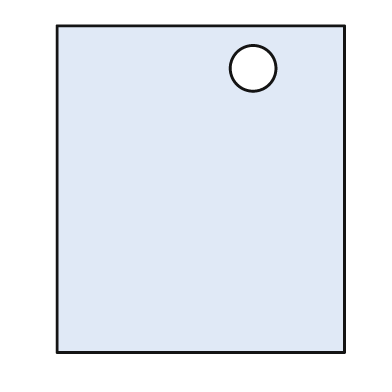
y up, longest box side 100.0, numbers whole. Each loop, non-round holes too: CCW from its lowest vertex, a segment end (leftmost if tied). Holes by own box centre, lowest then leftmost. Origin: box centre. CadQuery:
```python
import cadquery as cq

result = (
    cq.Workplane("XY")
    .moveTo(-44.0, -50.0)
    .lineTo(44.0, -50.0)
    .lineTo(44.0, 50.0)
    .lineTo(-44.0, 50.0)
    .close()
    .moveTo(16.0, 37.0)
    .circle(7.0)
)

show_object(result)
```